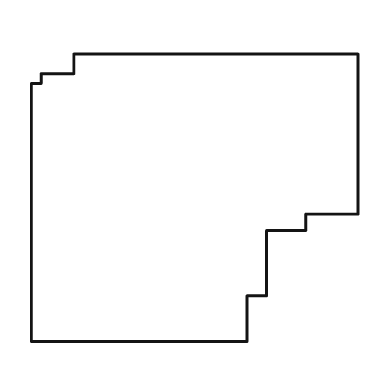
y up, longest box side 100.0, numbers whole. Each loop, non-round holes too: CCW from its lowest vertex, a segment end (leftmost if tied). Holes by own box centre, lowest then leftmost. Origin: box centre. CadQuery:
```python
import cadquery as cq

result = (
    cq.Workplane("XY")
    .moveTo(-50.0, -44.0)
    .lineTo(16.0, -44.0)
    .lineTo(16.0, -30.0)
    .lineTo(22.0, -30.0)
    .lineTo(22.0, -10.0)
    .lineTo(34.0, -10.0)
    .lineTo(34.0, -5.0)
    .lineTo(50.0, -5.0)
    .lineTo(50.0, 44.0)
    .lineTo(-37.0, 44.0)
    .lineTo(-37.0, 38.0)
    .lineTo(-47.0, 38.0)
    .lineTo(-47.0, 35.0)
    .lineTo(-50.0, 35.0)
    .close()
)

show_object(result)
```